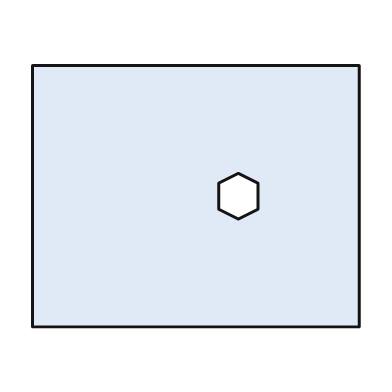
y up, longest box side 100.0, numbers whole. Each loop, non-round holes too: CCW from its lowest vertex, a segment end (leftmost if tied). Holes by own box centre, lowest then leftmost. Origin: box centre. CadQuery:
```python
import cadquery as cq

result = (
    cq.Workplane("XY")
    .moveTo(-50.0, -40.0)
    .lineTo(50.0, -40.0)
    .lineTo(50.0, 40.0)
    .lineTo(-50.0, 40.0)
    .close()
    .moveTo(13.0, -7.0)
    .lineTo(19.0, -4.0)
    .lineTo(19.0, 4.0)
    .lineTo(13.0, 7.0)
    .lineTo(7.0, 4.0)
    .lineTo(7.0, -4.0)
    .close()
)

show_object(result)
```